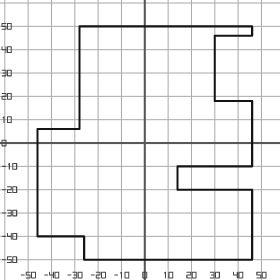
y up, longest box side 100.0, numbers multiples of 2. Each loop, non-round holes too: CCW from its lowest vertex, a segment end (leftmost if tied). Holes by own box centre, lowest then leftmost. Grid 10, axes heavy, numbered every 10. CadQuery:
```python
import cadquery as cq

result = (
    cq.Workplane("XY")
    .moveTo(-26.0, -50.0)
    .lineTo(46.0, -50.0)
    .lineTo(46.0, -20.0)
    .lineTo(14.0, -20.0)
    .lineTo(14.0, -10.0)
    .lineTo(46.0, -10.0)
    .lineTo(46.0, 18.0)
    .lineTo(30.0, 18.0)
    .lineTo(30.0, 46.0)
    .lineTo(46.0, 46.0)
    .lineTo(46.0, 50.0)
    .lineTo(-28.0, 50.0)
    .lineTo(-28.0, 6.0)
    .lineTo(-46.0, 6.0)
    .lineTo(-46.0, -40.0)
    .lineTo(-26.0, -40.0)
    .close()
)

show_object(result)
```